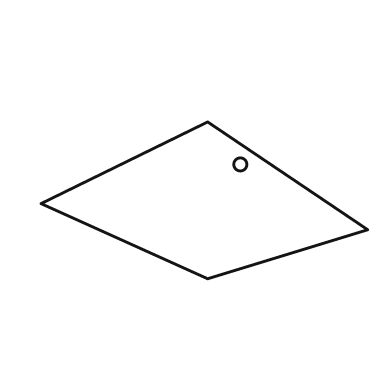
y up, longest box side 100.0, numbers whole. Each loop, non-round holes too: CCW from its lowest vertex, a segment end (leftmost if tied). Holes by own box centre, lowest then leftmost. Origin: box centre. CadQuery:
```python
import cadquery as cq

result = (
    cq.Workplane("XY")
    .moveTo(1.0, -24.0)
    .lineTo(50.0, -9.0)
    .lineTo(1.0, 24.0)
    .lineTo(-50.0, -1.0)
    .close()
    .moveTo(11.0, 11.0)
    .circle(2.0)
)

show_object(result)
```